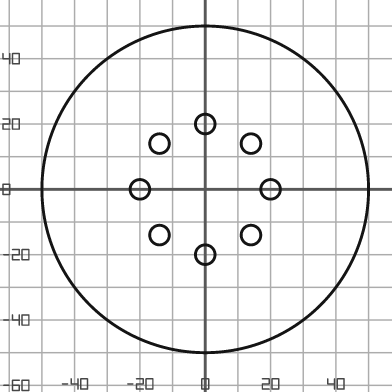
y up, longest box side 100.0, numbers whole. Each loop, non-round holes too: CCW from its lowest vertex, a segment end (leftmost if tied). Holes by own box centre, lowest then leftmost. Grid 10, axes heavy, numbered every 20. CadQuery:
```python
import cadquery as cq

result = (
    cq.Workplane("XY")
    .moveTo(0.0, 0.0)
    .circle(50.0)
    .moveTo(0.0, -20.0)
    .circle(3.0)
    .moveTo(-14.0, -14.0)
    .circle(3.0)
    .moveTo(14.0, -14.0)
    .circle(3.0)
    .moveTo(-20.0, 0.0)
    .circle(3.0)
    .moveTo(20.0, 0.0)
    .circle(3.0)
    .moveTo(-14.0, 14.0)
    .circle(3.0)
    .moveTo(14.0, 14.0)
    .circle(3.0)
    .moveTo(0.0, 20.0)
    .circle(3.0)
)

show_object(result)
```